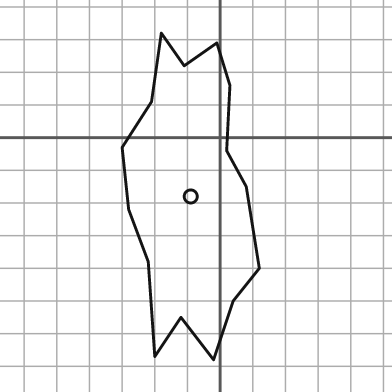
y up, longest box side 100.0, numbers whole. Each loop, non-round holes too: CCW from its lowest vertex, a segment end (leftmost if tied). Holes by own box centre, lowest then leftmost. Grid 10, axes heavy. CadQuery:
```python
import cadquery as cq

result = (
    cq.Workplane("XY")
    .moveTo(-2.0, -68.0)
    .lineTo(4.0, -50.0)
    .lineTo(12.0, -40.0)
    .lineTo(8.0, -15.0)
    .lineTo(2.0, -4.0)
    .lineTo(3.0, 16.0)
    .lineTo(-1.0, 29.0)
    .lineTo(-11.0, 22.0)
    .lineTo(-18.0, 32.0)
    .lineTo(-21.0, 11.0)
    .lineTo(-30.0, -3.0)
    .lineTo(-28.0, -22.0)
    .lineTo(-22.0, -38.0)
    .lineTo(-20.0, -67.0)
    .lineTo(-12.0, -55.0)
    .close()
    .moveTo(-9.0, -18.0)
    .circle(2.0)
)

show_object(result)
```